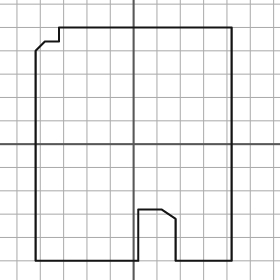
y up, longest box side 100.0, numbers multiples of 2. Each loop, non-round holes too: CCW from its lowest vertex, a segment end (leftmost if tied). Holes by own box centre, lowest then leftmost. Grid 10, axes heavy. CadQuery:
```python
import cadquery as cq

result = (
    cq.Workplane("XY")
    .moveTo(-42.0, -50.0)
    .lineTo(2.0, -50.0)
    .lineTo(2.0, -28.0)
    .lineTo(12.0, -28.0)
    .lineTo(18.0, -32.0)
    .lineTo(18.0, -50.0)
    .lineTo(42.0, -50.0)
    .lineTo(42.0, 50.0)
    .lineTo(-32.0, 50.0)
    .lineTo(-32.0, 44.0)
    .lineTo(-38.0, 44.0)
    .lineTo(-42.0, 40.0)
    .close()
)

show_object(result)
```